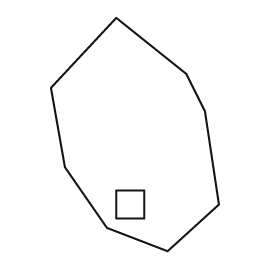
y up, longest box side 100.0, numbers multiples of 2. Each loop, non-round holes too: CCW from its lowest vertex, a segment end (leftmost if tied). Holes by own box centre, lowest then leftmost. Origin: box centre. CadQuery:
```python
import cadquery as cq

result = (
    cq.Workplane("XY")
    .moveTo(14.0, -50.0)
    .lineTo(36.0, -30.0)
    .lineTo(30.0, 10.0)
    .lineTo(22.0, 26.0)
    .lineTo(-8.0, 50.0)
    .lineTo(-36.0, 20.0)
    .lineTo(-30.0, -14.0)
    .lineTo(-12.0, -40.0)
    .close()
    .moveTo(-8.0, -36.0)
    .lineTo(4.0, -36.0)
    .lineTo(4.0, -24.0)
    .lineTo(-8.0, -24.0)
    .close()
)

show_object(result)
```